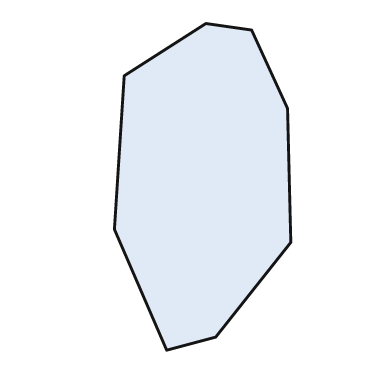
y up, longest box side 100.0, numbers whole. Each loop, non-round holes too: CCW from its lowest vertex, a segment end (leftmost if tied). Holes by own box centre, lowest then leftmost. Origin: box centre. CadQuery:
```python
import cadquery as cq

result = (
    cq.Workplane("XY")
    .moveTo(-11.0, -50.0)
    .lineTo(4.0, -46.0)
    .lineTo(27.0, -17.0)
    .lineTo(26.0, 24.0)
    .lineTo(15.0, 48.0)
    .lineTo(1.0, 50.0)
    .lineTo(-24.0, 34.0)
    .lineTo(-27.0, -13.0)
    .close()
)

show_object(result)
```